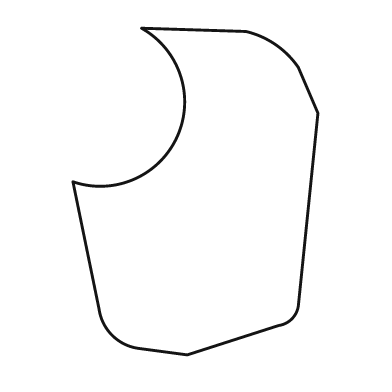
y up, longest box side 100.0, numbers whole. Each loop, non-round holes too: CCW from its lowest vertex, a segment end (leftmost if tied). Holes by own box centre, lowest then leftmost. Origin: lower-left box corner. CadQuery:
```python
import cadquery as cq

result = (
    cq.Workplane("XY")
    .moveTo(35.0, 0.0)
    .lineTo(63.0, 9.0)
    .threePointArc((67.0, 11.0), (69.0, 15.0))
    .lineTo(75.0, 74.0)
    .lineTo(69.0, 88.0)
    .threePointArc((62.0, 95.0), (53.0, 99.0))
    .lineTo(21.0, 100.0)
    .threePointArc((32.0, 67.0), (0.0, 53.0))
    .lineTo(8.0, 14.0)
    .threePointArc((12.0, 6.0), (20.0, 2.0))
    .close()
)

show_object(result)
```